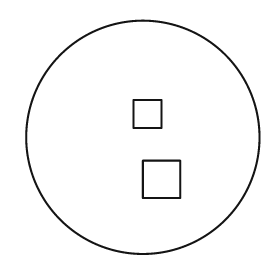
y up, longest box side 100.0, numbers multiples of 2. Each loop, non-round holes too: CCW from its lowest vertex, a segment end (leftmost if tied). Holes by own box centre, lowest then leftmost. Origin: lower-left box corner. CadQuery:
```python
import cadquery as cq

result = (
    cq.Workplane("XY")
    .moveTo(50.0, 50.0)
    .circle(50.0)
    .moveTo(50.0, 24.0)
    .lineTo(66.0, 24.0)
    .lineTo(66.0, 40.0)
    .lineTo(50.0, 40.0)
    .close()
    .moveTo(46.0, 54.0)
    .lineTo(58.0, 54.0)
    .lineTo(58.0, 66.0)
    .lineTo(46.0, 66.0)
    .close()
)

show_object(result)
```